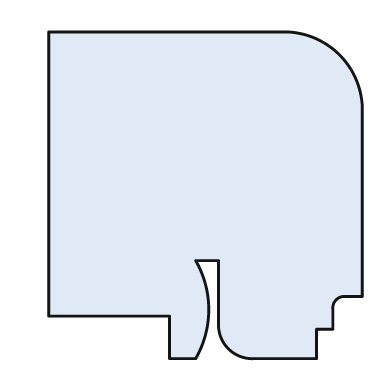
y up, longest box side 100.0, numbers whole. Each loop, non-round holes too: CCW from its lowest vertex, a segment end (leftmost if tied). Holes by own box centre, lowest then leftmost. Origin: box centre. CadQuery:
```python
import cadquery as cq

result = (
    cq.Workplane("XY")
    .moveTo(-11.0, -50.0)
    .lineTo(-3.0, -50.0)
    .threePointArc((1.0, -35.0), (-3.0, -20.0))
    .lineTo(4.0, -20.0)
    .lineTo(4.0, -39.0)
    .threePointArc((7.0, -47.0), (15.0, -50.0))
    .lineTo(34.0, -50.0)
    .lineTo(34.0, -41.0)
    .lineTo(39.0, -41.0)
    .lineTo(39.0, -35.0)
    .threePointArc((40.0, -32.0), (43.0, -31.0))
    .lineTo(48.0, -31.0)
    .lineTo(48.0, 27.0)
    .threePointArc((41.0, 43.0), (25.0, 50.0))
    .lineTo(-48.0, 50.0)
    .lineTo(-48.0, -37.0)
    .lineTo(-11.0, -37.0)
    .close()
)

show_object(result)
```